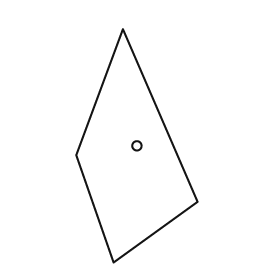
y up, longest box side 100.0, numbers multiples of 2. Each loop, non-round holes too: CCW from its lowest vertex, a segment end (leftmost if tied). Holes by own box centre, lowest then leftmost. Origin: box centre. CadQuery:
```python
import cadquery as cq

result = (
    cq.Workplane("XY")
    .moveTo(-10.0, -50.0)
    .lineTo(26.0, -24.0)
    .lineTo(-6.0, 50.0)
    .lineTo(-26.0, -4.0)
    .close()
    .moveTo(0.0, 0.0)
    .circle(2.0)
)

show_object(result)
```